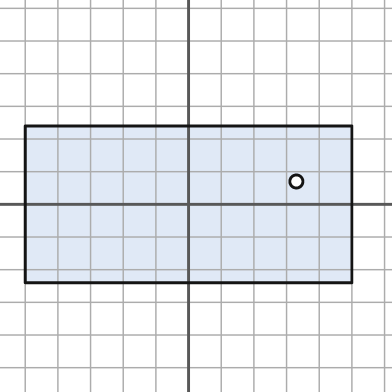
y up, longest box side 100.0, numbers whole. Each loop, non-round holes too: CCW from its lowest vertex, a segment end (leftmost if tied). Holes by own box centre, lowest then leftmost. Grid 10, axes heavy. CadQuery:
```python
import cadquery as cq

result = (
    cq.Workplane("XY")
    .moveTo(-50.0, -24.0)
    .lineTo(50.0, -24.0)
    .lineTo(50.0, 24.0)
    .lineTo(-50.0, 24.0)
    .close()
    .moveTo(33.0, 7.0)
    .circle(2.0)
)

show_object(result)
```